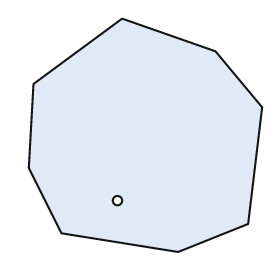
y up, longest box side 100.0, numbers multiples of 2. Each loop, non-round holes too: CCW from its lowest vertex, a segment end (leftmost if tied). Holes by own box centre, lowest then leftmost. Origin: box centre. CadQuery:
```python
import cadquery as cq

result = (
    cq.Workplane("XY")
    .moveTo(14.0, -50.0)
    .lineTo(44.0, -38.0)
    .lineTo(50.0, 12.0)
    .lineTo(30.0, 36.0)
    .lineTo(-10.0, 50.0)
    .lineTo(-48.0, 22.0)
    .lineTo(-50.0, -14.0)
    .lineTo(-36.0, -42.0)
    .close()
    .moveTo(-12.0, -28.0)
    .circle(2.0)
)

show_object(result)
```